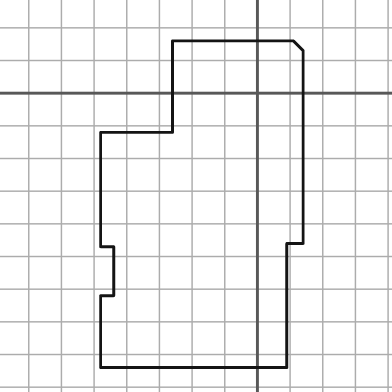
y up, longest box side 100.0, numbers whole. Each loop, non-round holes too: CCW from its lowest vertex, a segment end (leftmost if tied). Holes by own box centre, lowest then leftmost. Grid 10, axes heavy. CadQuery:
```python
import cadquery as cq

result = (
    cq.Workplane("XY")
    .moveTo(-48.0, -84.0)
    .lineTo(9.0, -84.0)
    .lineTo(9.0, -46.0)
    .lineTo(14.0, -46.0)
    .lineTo(14.0, 13.0)
    .lineTo(11.0, 16.0)
    .lineTo(-26.0, 16.0)
    .lineTo(-26.0, -12.0)
    .lineTo(-48.0, -12.0)
    .lineTo(-48.0, -47.0)
    .lineTo(-44.0, -47.0)
    .lineTo(-44.0, -62.0)
    .lineTo(-48.0, -62.0)
    .close()
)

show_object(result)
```